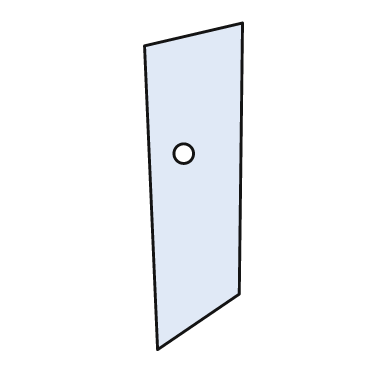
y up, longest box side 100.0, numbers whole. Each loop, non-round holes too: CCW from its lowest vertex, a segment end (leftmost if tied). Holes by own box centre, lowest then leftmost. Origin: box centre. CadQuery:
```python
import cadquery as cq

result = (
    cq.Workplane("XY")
    .moveTo(-11.0, -50.0)
    .lineTo(14.0, -33.0)
    .lineTo(15.0, 50.0)
    .lineTo(-15.0, 43.0)
    .close()
    .moveTo(-3.0, 10.0)
    .circle(3.0)
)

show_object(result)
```